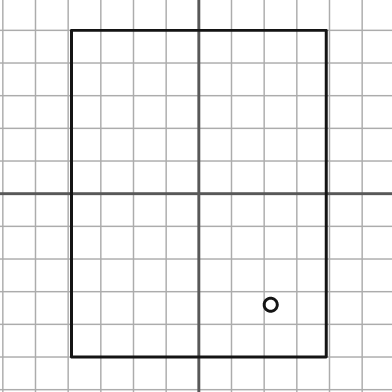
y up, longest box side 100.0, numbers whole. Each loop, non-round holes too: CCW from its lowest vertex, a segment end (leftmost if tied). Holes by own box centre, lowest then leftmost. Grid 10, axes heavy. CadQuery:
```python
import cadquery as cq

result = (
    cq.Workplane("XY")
    .moveTo(-39.0, -50.0)
    .lineTo(39.0, -50.0)
    .lineTo(39.0, 50.0)
    .lineTo(-39.0, 50.0)
    .close()
    .moveTo(22.0, -34.0)
    .circle(2.0)
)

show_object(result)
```